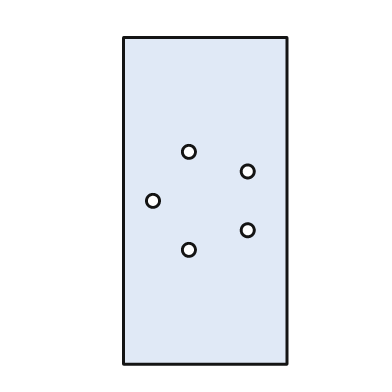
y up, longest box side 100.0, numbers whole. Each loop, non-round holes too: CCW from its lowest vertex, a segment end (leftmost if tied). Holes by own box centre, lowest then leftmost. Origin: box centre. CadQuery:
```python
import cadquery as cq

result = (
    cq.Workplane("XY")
    .moveTo(-25.0, -50.0)
    .lineTo(25.0, -50.0)
    .lineTo(25.0, 50.0)
    .lineTo(-25.0, 50.0)
    .close()
    .moveTo(-5.0, -15.0)
    .circle(2.0)
    .moveTo(13.0, -9.0)
    .circle(2.0)
    .moveTo(-16.0, 0.0)
    .circle(2.0)
    .moveTo(13.0, 9.0)
    .circle(2.0)
    .moveTo(-5.0, 15.0)
    .circle(2.0)
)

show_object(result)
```